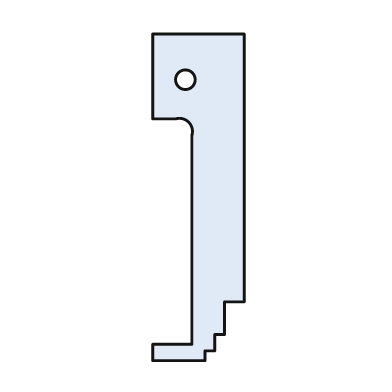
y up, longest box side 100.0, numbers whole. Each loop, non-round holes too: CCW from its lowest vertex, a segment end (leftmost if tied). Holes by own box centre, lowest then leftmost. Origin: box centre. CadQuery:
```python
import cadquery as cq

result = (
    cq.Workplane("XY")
    .moveTo(-14.0, -50.0)
    .lineTo(2.0, -50.0)
    .lineTo(2.0, -47.0)
    .lineTo(5.0, -47.0)
    .lineTo(5.0, -42.0)
    .lineTo(8.0, -42.0)
    .lineTo(8.0, -32.0)
    .lineTo(14.0, -32.0)
    .lineTo(14.0, 50.0)
    .lineTo(-14.0, 50.0)
    .lineTo(-14.0, 24.0)
    .lineTo(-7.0, 24.0)
    .threePointArc((-3.0, 23.0), (-2.0, 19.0))
    .lineTo(-2.0, -45.0)
    .lineTo(-14.0, -45.0)
    .close()
    .moveTo(-4.0, 36.0)
    .circle(3.0)
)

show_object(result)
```